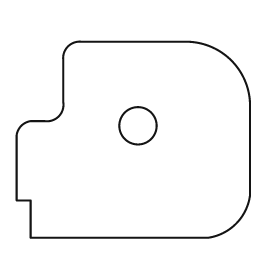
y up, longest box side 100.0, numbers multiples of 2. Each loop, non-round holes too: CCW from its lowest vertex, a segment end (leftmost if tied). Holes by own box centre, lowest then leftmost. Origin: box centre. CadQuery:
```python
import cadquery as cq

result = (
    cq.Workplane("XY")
    .moveTo(-44.0, -42.0)
    .lineTo(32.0, -42.0)
    .threePointArc((44.0, -36.0), (50.0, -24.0))
    .lineTo(50.0, 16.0)
    .threePointArc((42.0, 34.0), (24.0, 42.0))
    .lineTo(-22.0, 42.0)
    .threePointArc((-28.0, 40.0), (-30.0, 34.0))
    .lineTo(-30.0, 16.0)
    .threePointArc((-32.0, 10.0), (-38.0, 8.0))
    .lineTo(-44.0, 8.0)
    .threePointArc((-48.0, 6.0), (-50.0, 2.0))
    .lineTo(-50.0, -26.0)
    .lineTo(-44.0, -26.0)
    .close()
    .moveTo(2.0, 6.0)
    .circle(8.0)
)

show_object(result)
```